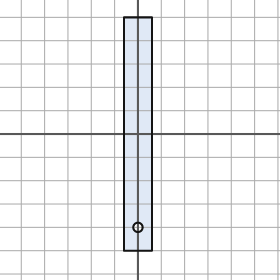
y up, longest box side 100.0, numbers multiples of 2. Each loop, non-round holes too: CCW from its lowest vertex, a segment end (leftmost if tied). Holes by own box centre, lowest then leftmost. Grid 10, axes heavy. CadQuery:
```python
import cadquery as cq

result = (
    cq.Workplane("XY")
    .moveTo(-6.0, -50.0)
    .lineTo(6.0, -50.0)
    .lineTo(6.0, 50.0)
    .lineTo(-6.0, 50.0)
    .close()
    .moveTo(0.0, -40.0)
    .circle(2.0)
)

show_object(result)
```